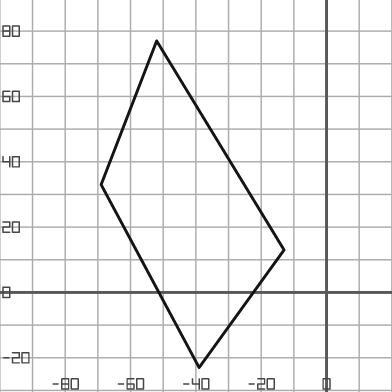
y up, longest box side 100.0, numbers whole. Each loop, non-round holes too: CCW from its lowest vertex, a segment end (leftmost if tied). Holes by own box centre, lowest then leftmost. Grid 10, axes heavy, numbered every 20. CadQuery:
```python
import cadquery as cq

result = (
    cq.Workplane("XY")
    .moveTo(-39.0, -23.0)
    .lineTo(-13.0, 13.0)
    .lineTo(-52.0, 77.0)
    .lineTo(-69.0, 33.0)
    .close()
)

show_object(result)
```